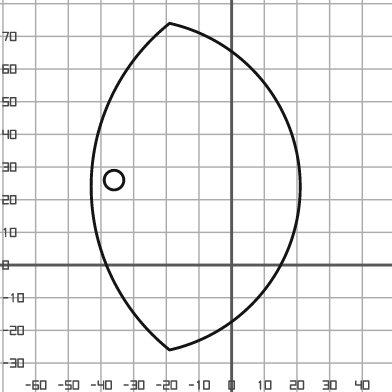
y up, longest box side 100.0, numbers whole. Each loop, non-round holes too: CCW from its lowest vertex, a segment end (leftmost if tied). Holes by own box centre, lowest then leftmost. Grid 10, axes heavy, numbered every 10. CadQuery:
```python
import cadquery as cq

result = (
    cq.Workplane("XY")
    .moveTo(-19.0, -26.0)
    .threePointArc((21.0, 24.0), (-19.0, 74.0))
    .threePointArc((-43.0, 24.0), (-19.0, -26.0))
    .close()
    .moveTo(-36.0, 26.0)
    .circle(3.0)
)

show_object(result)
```